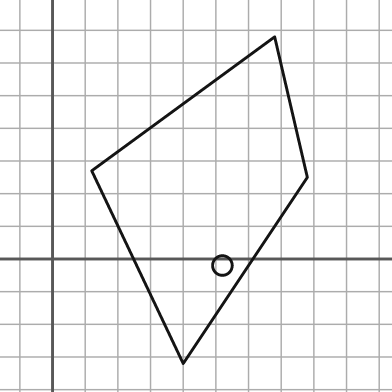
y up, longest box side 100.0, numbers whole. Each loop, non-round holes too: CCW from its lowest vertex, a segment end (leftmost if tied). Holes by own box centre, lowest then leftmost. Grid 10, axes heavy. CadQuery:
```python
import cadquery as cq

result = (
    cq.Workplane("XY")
    .moveTo(40.0, -32.0)
    .lineTo(78.0, 25.0)
    .lineTo(68.0, 68.0)
    .lineTo(12.0, 27.0)
    .close()
    .moveTo(52.0, -2.0)
    .circle(3.0)
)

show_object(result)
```